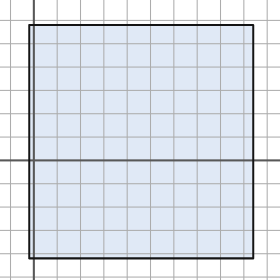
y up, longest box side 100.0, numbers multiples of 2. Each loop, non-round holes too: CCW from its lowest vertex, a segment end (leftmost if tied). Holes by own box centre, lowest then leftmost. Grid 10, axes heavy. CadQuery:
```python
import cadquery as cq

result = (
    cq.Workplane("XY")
    .moveTo(-2.0, -42.0)
    .lineTo(94.0, -42.0)
    .lineTo(94.0, 58.0)
    .lineTo(-2.0, 58.0)
    .close()
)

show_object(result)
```